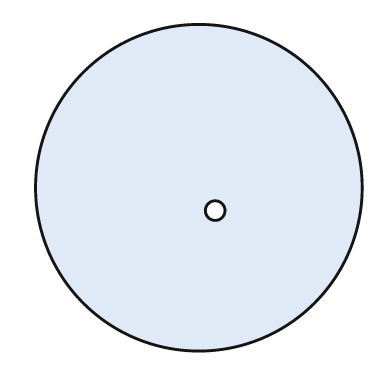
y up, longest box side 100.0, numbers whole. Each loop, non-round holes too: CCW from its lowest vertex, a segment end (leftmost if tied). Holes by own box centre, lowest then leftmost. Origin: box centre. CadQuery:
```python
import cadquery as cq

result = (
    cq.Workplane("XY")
    .moveTo(0.0, 0.0)
    .circle(50.0)
    .moveTo(5.0, -7.0)
    .circle(3.0)
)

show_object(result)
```